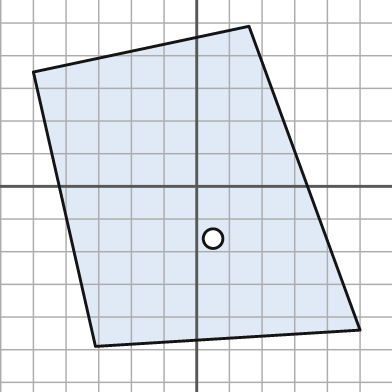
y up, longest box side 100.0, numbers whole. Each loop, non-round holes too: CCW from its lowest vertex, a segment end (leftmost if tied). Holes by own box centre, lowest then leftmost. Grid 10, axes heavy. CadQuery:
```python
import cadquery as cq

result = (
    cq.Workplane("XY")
    .moveTo(-31.0, -49.0)
    .lineTo(50.0, -44.0)
    .lineTo(16.0, 49.0)
    .lineTo(-50.0, 35.0)
    .close()
    .moveTo(5.0, -16.0)
    .circle(3.0)
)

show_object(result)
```